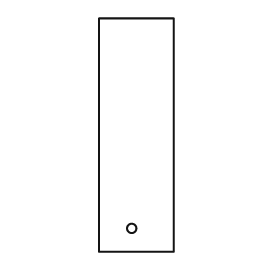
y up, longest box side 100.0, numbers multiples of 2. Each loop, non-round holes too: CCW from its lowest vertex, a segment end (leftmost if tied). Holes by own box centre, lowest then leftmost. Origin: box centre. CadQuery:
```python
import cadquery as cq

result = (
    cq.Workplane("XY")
    .moveTo(-16.0, -50.0)
    .lineTo(16.0, -50.0)
    .lineTo(16.0, 50.0)
    .lineTo(-16.0, 50.0)
    .close()
    .moveTo(-2.0, -40.0)
    .circle(2.0)
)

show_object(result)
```